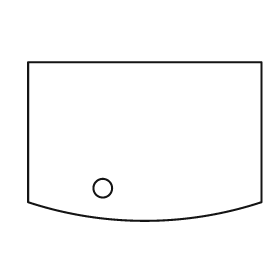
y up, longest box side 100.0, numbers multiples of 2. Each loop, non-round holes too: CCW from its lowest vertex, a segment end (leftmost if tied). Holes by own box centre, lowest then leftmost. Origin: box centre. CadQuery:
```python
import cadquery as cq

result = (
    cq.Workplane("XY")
    .moveTo(-50.0, -26.0)
    .threePointArc((0.0, -34.0), (50.0, -26.0))
    .lineTo(50.0, 34.0)
    .lineTo(-50.0, 34.0)
    .close()
    .moveTo(-18.0, -20.0)
    .circle(4.0)
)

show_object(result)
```